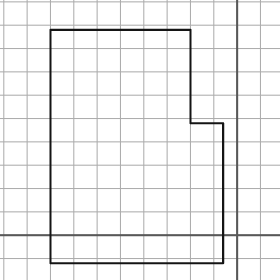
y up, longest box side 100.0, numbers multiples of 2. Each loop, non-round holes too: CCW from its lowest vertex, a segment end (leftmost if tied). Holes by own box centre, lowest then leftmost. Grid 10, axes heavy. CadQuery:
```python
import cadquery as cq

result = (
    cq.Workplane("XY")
    .moveTo(-80.0, -12.0)
    .lineTo(-6.0, -12.0)
    .lineTo(-6.0, 48.0)
    .lineTo(-20.0, 48.0)
    .lineTo(-20.0, 88.0)
    .lineTo(-80.0, 88.0)
    .close()
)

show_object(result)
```